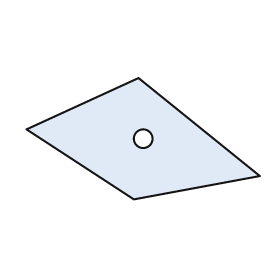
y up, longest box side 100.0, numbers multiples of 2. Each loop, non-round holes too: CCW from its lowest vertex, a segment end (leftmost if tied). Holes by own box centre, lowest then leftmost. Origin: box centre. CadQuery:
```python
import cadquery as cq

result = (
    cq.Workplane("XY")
    .moveTo(-4.0, -26.0)
    .lineTo(50.0, -16.0)
    .lineTo(-2.0, 26.0)
    .lineTo(-50.0, 4.0)
    .close()
    .moveTo(0.0, 0.0)
    .circle(4.0)
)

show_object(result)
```